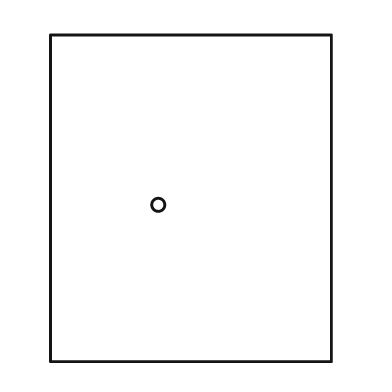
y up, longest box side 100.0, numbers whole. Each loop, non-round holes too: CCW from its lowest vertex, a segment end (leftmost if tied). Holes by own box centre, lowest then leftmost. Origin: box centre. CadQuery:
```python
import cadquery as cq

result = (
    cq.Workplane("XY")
    .moveTo(-43.0, -50.0)
    .lineTo(43.0, -50.0)
    .lineTo(43.0, 50.0)
    .lineTo(-43.0, 50.0)
    .close()
    .moveTo(-10.0, -2.0)
    .circle(2.0)
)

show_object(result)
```